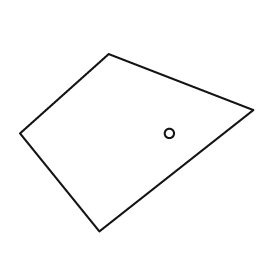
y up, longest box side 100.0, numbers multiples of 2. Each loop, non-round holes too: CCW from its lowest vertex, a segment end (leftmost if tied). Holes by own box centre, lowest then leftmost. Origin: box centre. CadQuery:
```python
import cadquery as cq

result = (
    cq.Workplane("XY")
    .moveTo(-16.0, -38.0)
    .lineTo(50.0, 14.0)
    .lineTo(-12.0, 38.0)
    .lineTo(-50.0, 4.0)
    .close()
    .moveTo(14.0, 4.0)
    .circle(2.0)
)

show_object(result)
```